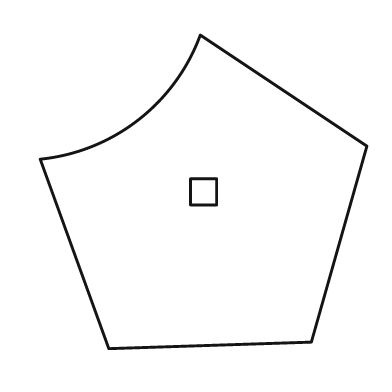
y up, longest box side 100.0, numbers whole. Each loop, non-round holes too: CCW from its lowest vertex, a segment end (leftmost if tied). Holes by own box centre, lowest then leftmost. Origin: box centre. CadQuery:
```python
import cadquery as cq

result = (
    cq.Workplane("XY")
    .moveTo(-29.0, -48.0)
    .lineTo(33.0, -46.0)
    .lineTo(50.0, 14.0)
    .lineTo(-1.0, 48.0)
    .threePointArc((-20.0, 22.0), (-50.0, 10.0))
    .close()
    .moveTo(-4.0, -4.0)
    .lineTo(4.0, -4.0)
    .lineTo(4.0, 4.0)
    .lineTo(-4.0, 4.0)
    .close()
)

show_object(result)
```